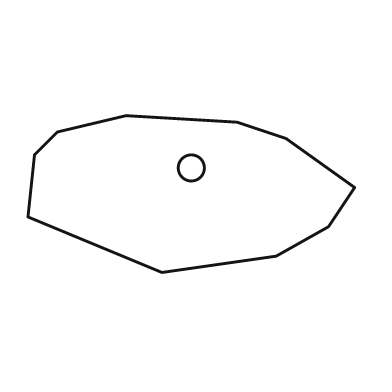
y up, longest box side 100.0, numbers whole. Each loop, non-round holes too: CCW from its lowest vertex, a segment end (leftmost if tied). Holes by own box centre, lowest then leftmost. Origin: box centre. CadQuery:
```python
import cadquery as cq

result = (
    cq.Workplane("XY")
    .moveTo(-9.0, -24.0)
    .lineTo(26.0, -19.0)
    .lineTo(42.0, -10.0)
    .lineTo(50.0, 2.0)
    .lineTo(29.0, 17.0)
    .lineTo(14.0, 22.0)
    .lineTo(-20.0, 24.0)
    .lineTo(-41.0, 19.0)
    .lineTo(-48.0, 12.0)
    .lineTo(-50.0, -7.0)
    .close()
    .moveTo(0.0, 8.0)
    .circle(4.0)
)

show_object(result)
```